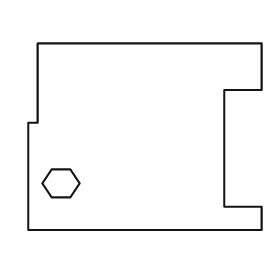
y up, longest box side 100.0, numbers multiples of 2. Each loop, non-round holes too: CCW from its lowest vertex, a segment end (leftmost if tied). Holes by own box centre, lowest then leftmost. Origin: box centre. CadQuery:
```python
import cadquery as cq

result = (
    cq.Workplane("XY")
    .moveTo(-50.0, -40.0)
    .lineTo(50.0, -40.0)
    .lineTo(50.0, -30.0)
    .lineTo(34.0, -30.0)
    .lineTo(34.0, 20.0)
    .lineTo(50.0, 20.0)
    .lineTo(50.0, 40.0)
    .lineTo(-46.0, 40.0)
    .lineTo(-46.0, 6.0)
    .lineTo(-50.0, 6.0)
    .close()
    .moveTo(-40.0, -26.0)
    .lineTo(-32.0, -26.0)
    .lineTo(-28.0, -20.0)
    .lineTo(-32.0, -14.0)
    .lineTo(-40.0, -14.0)
    .lineTo(-44.0, -20.0)
    .close()
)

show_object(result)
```